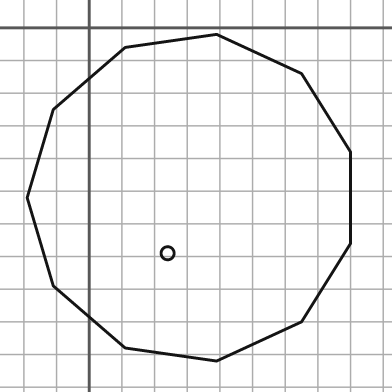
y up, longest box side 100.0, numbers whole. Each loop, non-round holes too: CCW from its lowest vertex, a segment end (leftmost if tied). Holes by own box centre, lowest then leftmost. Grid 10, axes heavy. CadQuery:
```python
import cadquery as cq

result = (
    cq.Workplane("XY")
    .moveTo(39.0, -102.0)
    .lineTo(65.0, -90.0)
    .lineTo(80.0, -66.0)
    .lineTo(80.0, -38.0)
    .lineTo(65.0, -14.0)
    .lineTo(39.0, -2.0)
    .lineTo(11.0, -6.0)
    .lineTo(-11.0, -25.0)
    .lineTo(-19.0, -52.0)
    .lineTo(-11.0, -79.0)
    .lineTo(11.0, -98.0)
    .close()
    .moveTo(24.0, -69.0)
    .circle(2.0)
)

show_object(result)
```